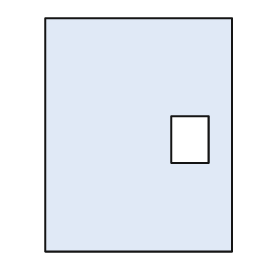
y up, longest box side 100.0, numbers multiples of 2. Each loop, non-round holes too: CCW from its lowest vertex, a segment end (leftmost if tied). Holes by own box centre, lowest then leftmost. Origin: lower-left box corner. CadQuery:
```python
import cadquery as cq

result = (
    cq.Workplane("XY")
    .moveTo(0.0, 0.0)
    .lineTo(80.0, 0.0)
    .lineTo(80.0, 100.0)
    .lineTo(0.0, 100.0)
    .close()
    .moveTo(54.0, 38.0)
    .lineTo(70.0, 38.0)
    .lineTo(70.0, 58.0)
    .lineTo(54.0, 58.0)
    .close()
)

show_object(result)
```